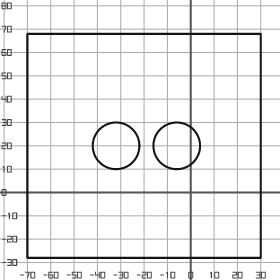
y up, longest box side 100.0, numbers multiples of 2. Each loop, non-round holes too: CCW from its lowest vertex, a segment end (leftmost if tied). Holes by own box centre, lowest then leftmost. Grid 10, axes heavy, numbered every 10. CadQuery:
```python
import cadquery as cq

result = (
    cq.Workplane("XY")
    .moveTo(-70.0, -28.0)
    .lineTo(30.0, -28.0)
    .lineTo(30.0, 68.0)
    .lineTo(-70.0, 68.0)
    .close()
    .moveTo(-32.0, 20.0)
    .circle(10.0)
    .moveTo(-6.0, 20.0)
    .circle(10.0)
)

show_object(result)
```